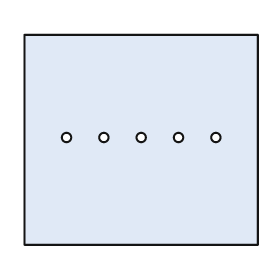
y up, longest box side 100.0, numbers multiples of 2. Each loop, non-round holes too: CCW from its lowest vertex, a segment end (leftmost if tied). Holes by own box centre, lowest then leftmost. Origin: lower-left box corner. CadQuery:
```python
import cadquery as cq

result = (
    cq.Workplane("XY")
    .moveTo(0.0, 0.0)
    .lineTo(100.0, 0.0)
    .lineTo(100.0, 90.0)
    .lineTo(0.0, 90.0)
    .close()
    .moveTo(18.0, 46.0)
    .circle(2.0)
    .moveTo(34.0, 46.0)
    .circle(2.0)
    .moveTo(50.0, 46.0)
    .circle(2.0)
    .moveTo(66.0, 46.0)
    .circle(2.0)
    .moveTo(82.0, 46.0)
    .circle(2.0)
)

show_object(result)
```